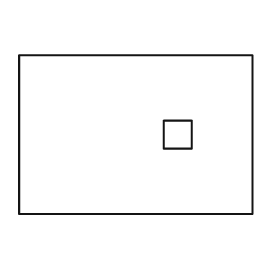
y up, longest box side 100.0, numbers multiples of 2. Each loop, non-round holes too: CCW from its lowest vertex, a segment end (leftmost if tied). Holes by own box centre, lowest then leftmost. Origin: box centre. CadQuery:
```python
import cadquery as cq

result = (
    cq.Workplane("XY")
    .moveTo(-50.0, -34.0)
    .lineTo(50.0, -34.0)
    .lineTo(50.0, 34.0)
    .lineTo(-50.0, 34.0)
    .close()
    .moveTo(12.0, -6.0)
    .lineTo(24.0, -6.0)
    .lineTo(24.0, 6.0)
    .lineTo(12.0, 6.0)
    .close()
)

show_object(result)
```